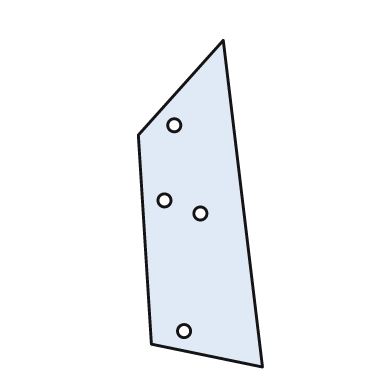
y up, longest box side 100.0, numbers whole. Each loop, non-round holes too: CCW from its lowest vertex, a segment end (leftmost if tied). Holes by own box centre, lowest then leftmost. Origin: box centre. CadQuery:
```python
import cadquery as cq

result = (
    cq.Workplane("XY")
    .moveTo(19.0, -50.0)
    .lineTo(7.0, 50.0)
    .lineTo(-19.0, 21.0)
    .lineTo(-15.0, -43.0)
    .close()
    .moveTo(-5.0, -39.0)
    .circle(2.0)
    .moveTo(0.0, -3.0)
    .circle(2.0)
    .moveTo(-11.0, 1.0)
    .circle(2.0)
    .moveTo(-8.0, 24.0)
    .circle(2.0)
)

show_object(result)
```